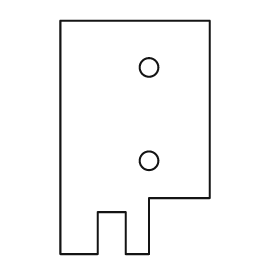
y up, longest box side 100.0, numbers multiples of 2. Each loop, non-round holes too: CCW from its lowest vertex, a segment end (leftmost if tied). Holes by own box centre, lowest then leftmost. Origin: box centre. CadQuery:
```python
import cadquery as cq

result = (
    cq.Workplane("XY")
    .moveTo(-32.0, -50.0)
    .lineTo(-16.0, -50.0)
    .lineTo(-16.0, -32.0)
    .lineTo(-4.0, -32.0)
    .lineTo(-4.0, -50.0)
    .lineTo(6.0, -50.0)
    .lineTo(6.0, -26.0)
    .lineTo(32.0, -26.0)
    .lineTo(32.0, 50.0)
    .lineTo(-32.0, 50.0)
    .close()
    .moveTo(6.0, -10.0)
    .circle(4.0)
    .moveTo(6.0, 30.0)
    .circle(4.0)
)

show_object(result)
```